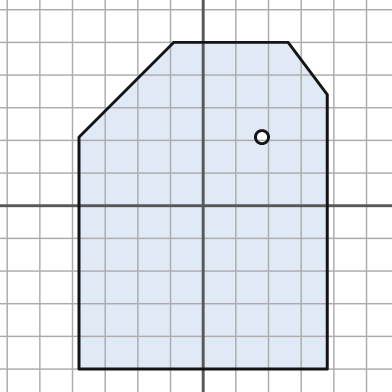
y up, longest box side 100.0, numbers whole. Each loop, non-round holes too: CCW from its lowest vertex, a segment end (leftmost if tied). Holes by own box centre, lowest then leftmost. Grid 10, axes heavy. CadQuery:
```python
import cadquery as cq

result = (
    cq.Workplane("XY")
    .moveTo(-38.0, -50.0)
    .lineTo(38.0, -50.0)
    .lineTo(38.0, 34.0)
    .lineTo(26.0, 50.0)
    .lineTo(-9.0, 50.0)
    .lineTo(-38.0, 21.0)
    .close()
    .moveTo(18.0, 21.0)
    .circle(2.0)
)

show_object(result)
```